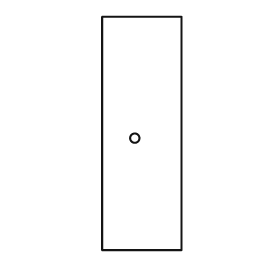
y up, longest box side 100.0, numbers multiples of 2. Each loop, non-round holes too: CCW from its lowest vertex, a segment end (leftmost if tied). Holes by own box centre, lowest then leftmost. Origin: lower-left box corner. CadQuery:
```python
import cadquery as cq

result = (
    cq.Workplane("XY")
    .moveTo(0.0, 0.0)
    .lineTo(34.0, 0.0)
    .lineTo(34.0, 100.0)
    .lineTo(0.0, 100.0)
    .close()
    .moveTo(14.0, 48.0)
    .circle(2.0)
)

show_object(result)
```